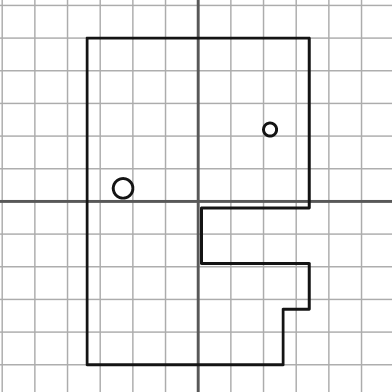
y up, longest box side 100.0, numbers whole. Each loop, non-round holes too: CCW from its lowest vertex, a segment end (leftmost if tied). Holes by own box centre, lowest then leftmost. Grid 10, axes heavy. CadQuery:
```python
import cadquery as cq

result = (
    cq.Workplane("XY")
    .moveTo(-34.0, -50.0)
    .lineTo(26.0, -50.0)
    .lineTo(26.0, -33.0)
    .lineTo(34.0, -33.0)
    .lineTo(34.0, -19.0)
    .lineTo(1.0, -19.0)
    .lineTo(1.0, -2.0)
    .lineTo(34.0, -2.0)
    .lineTo(34.0, 50.0)
    .lineTo(-34.0, 50.0)
    .close()
    .moveTo(-23.0, 4.0)
    .circle(3.0)
    .moveTo(22.0, 22.0)
    .circle(2.0)
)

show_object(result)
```